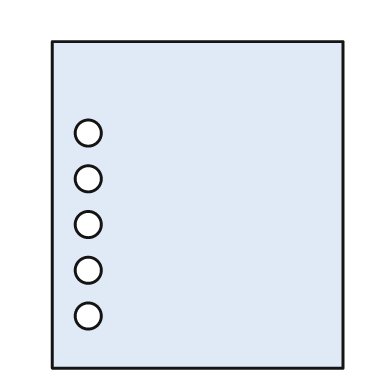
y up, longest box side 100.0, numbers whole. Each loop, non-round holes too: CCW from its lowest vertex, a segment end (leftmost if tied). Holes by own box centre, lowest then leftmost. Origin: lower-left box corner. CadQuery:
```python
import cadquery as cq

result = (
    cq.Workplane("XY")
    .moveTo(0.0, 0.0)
    .lineTo(89.0, 0.0)
    .lineTo(89.0, 100.0)
    .lineTo(0.0, 100.0)
    .close()
    .moveTo(11.0, 16.0)
    .circle(4.0)
    .moveTo(11.0, 30.0)
    .circle(4.0)
    .moveTo(11.0, 44.0)
    .circle(4.0)
    .moveTo(11.0, 58.0)
    .circle(4.0)
    .moveTo(11.0, 72.0)
    .circle(4.0)
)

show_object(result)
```